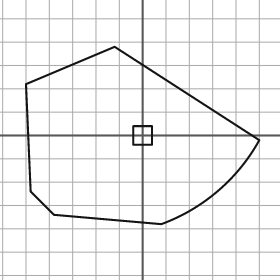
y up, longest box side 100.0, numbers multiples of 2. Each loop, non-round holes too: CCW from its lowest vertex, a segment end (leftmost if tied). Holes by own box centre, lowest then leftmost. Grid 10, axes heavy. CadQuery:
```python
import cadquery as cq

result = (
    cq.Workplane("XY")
    .moveTo(8.0, -38.0)
    .threePointArc((32.0, -24.0), (50.0, -2.0))
    .lineTo(-12.0, 38.0)
    .lineTo(-50.0, 22.0)
    .lineTo(-48.0, -24.0)
    .lineTo(-38.0, -34.0)
    .close()
    .moveTo(-4.0, -4.0)
    .lineTo(4.0, -4.0)
    .lineTo(4.0, 4.0)
    .lineTo(-4.0, 4.0)
    .close()
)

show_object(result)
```